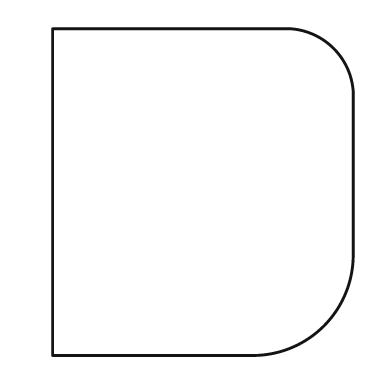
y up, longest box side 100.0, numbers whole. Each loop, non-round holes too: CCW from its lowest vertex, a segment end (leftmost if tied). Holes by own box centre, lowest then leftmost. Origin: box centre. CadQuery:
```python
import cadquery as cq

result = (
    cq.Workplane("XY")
    .moveTo(-46.0, -50.0)
    .lineTo(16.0, -50.0)
    .threePointArc((37.0, -41.0), (46.0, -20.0))
    .lineTo(46.0, 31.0)
    .threePointArc((40.0, 44.0), (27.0, 50.0))
    .lineTo(-46.0, 50.0)
    .close()
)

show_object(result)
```